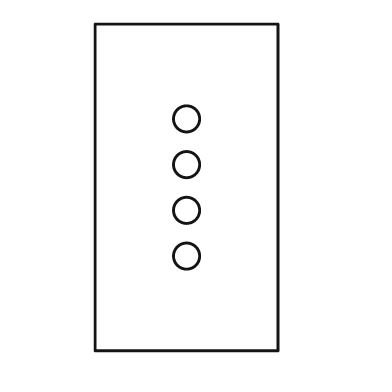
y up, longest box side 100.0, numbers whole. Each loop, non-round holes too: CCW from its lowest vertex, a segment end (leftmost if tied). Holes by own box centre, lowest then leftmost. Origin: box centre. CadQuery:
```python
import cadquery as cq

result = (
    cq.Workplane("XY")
    .moveTo(-28.0, -50.0)
    .lineTo(28.0, -50.0)
    .lineTo(28.0, 50.0)
    .lineTo(-28.0, 50.0)
    .close()
    .moveTo(0.0, -21.0)
    .circle(4.0)
    .moveTo(0.0, -7.0)
    .circle(4.0)
    .moveTo(0.0, 7.0)
    .circle(4.0)
    .moveTo(0.0, 21.0)
    .circle(4.0)
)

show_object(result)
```